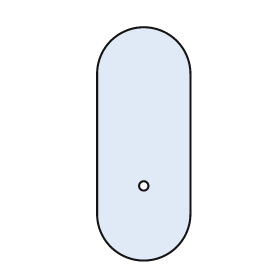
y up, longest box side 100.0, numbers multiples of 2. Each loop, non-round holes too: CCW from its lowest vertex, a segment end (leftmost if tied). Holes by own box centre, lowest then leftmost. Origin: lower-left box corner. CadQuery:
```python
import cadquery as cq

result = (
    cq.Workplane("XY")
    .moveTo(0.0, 20.0)
    .threePointArc((20.0, 0.0), (40.0, 20.0))
    .lineTo(40.0, 80.0)
    .threePointArc((20.0, 100.0), (0.0, 80.0))
    .close()
    .moveTo(20.0, 32.0)
    .circle(2.0)
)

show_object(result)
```